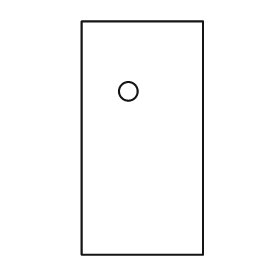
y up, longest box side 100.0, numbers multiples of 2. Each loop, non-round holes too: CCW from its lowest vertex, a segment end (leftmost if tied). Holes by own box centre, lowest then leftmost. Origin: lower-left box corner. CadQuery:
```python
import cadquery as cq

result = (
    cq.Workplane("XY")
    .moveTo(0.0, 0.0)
    .lineTo(52.0, 0.0)
    .lineTo(52.0, 100.0)
    .lineTo(0.0, 100.0)
    .close()
    .moveTo(20.0, 70.0)
    .circle(4.0)
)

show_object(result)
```